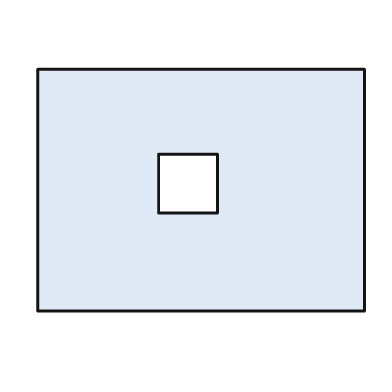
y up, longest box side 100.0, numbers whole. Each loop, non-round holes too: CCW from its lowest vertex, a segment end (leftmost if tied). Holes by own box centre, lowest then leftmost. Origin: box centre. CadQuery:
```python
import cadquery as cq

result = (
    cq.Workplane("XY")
    .moveTo(-50.0, -37.0)
    .lineTo(50.0, -37.0)
    .lineTo(50.0, 37.0)
    .lineTo(-50.0, 37.0)
    .close()
    .moveTo(-13.0, -7.0)
    .lineTo(5.0, -7.0)
    .lineTo(5.0, 11.0)
    .lineTo(-13.0, 11.0)
    .close()
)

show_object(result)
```